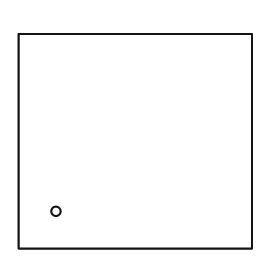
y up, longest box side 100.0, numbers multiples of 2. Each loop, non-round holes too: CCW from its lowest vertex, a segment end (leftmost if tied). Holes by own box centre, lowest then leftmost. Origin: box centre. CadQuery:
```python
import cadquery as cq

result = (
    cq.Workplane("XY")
    .moveTo(-50.0, -46.0)
    .lineTo(50.0, -46.0)
    .lineTo(50.0, 46.0)
    .lineTo(-50.0, 46.0)
    .close()
    .moveTo(-34.0, -30.0)
    .circle(2.0)
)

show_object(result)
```